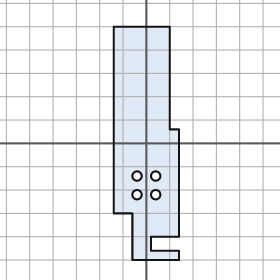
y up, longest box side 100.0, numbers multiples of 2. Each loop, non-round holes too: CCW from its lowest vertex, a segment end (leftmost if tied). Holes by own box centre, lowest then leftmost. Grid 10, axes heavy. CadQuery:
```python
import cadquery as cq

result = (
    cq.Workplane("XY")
    .moveTo(-6.0, -50.0)
    .lineTo(14.0, -50.0)
    .lineTo(14.0, -46.0)
    .lineTo(2.0, -46.0)
    .lineTo(2.0, -40.0)
    .lineTo(14.0, -40.0)
    .lineTo(14.0, 6.0)
    .lineTo(10.0, 6.0)
    .lineTo(10.0, 50.0)
    .lineTo(-14.0, 50.0)
    .lineTo(-14.0, -30.0)
    .lineTo(-6.0, -30.0)
    .close()
    .moveTo(-4.0, -22.0)
    .circle(2.0)
    .moveTo(4.0, -22.0)
    .circle(2.0)
    .moveTo(-4.0, -14.0)
    .circle(2.0)
    .moveTo(4.0, -14.0)
    .circle(2.0)
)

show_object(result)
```